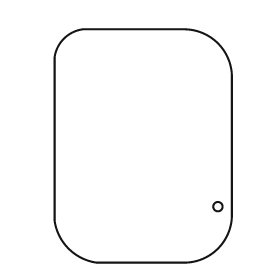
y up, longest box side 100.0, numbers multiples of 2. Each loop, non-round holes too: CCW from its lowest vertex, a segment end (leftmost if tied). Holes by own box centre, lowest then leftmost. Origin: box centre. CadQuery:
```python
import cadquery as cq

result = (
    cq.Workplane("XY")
    .moveTo(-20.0, -50.0)
    .lineTo(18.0, -50.0)
    .threePointArc((32.0, -44.0), (38.0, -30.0))
    .lineTo(38.0, 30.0)
    .threePointArc((32.0, 44.0), (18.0, 50.0))
    .lineTo(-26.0, 50.0)
    .threePointArc((-34.0, 46.0), (-38.0, 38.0))
    .lineTo(-38.0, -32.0)
    .threePointArc((-32.0, -44.0), (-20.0, -50.0))
    .close()
    .moveTo(32.0, -26.0)
    .circle(2.0)
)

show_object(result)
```